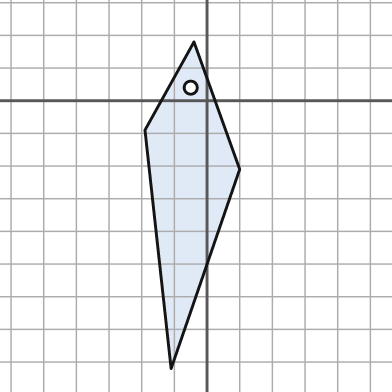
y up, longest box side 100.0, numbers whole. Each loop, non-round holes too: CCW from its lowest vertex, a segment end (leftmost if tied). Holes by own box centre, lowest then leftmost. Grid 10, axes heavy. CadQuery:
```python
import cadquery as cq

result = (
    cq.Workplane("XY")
    .moveTo(-11.0, -82.0)
    .lineTo(10.0, -21.0)
    .lineTo(-4.0, 18.0)
    .lineTo(-19.0, -9.0)
    .close()
    .moveTo(-5.0, 4.0)
    .circle(2.0)
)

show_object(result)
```